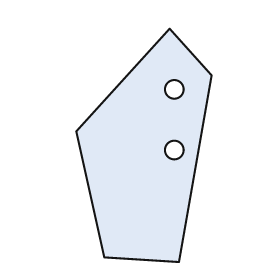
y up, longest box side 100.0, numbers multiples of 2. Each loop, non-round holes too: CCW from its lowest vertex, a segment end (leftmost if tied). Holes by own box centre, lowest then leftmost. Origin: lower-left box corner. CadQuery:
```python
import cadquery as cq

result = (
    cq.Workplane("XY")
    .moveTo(44.0, 0.0)
    .lineTo(58.0, 80.0)
    .lineTo(40.0, 100.0)
    .lineTo(0.0, 56.0)
    .lineTo(12.0, 2.0)
    .close()
    .moveTo(42.0, 48.0)
    .circle(4.0)
    .moveTo(42.0, 74.0)
    .circle(4.0)
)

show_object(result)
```